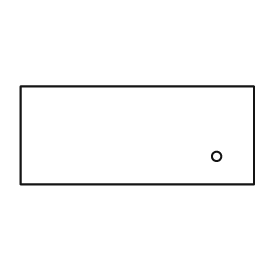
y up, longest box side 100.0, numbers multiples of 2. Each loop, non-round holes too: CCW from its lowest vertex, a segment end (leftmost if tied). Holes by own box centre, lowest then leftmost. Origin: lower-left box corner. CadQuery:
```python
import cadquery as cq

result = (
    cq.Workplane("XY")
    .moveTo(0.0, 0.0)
    .lineTo(100.0, 0.0)
    .lineTo(100.0, 42.0)
    .lineTo(0.0, 42.0)
    .close()
    .moveTo(84.0, 12.0)
    .circle(2.0)
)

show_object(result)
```